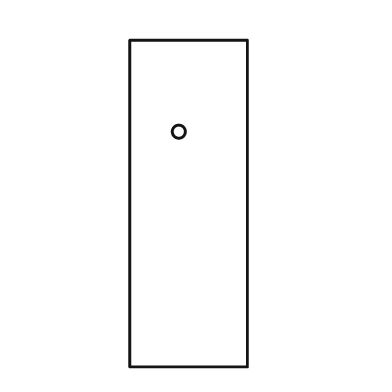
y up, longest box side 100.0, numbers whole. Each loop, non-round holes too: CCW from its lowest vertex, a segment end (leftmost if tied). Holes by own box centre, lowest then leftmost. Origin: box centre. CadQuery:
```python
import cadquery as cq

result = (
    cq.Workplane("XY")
    .moveTo(-18.0, -50.0)
    .lineTo(18.0, -50.0)
    .lineTo(18.0, 50.0)
    .lineTo(-18.0, 50.0)
    .close()
    .moveTo(-3.0, 22.0)
    .circle(2.0)
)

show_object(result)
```